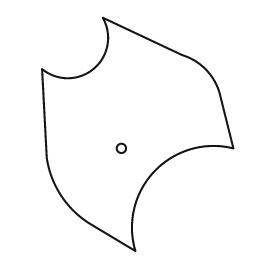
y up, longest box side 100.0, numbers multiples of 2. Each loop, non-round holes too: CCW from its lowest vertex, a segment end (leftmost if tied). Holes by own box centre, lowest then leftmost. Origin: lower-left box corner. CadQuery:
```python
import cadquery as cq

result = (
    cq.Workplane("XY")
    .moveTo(40.0, 0.0)
    .threePointArc((48.0, 34.0), (82.0, 44.0))
    .lineTo(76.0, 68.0)
    .threePointArc((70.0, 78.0), (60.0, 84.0))
    .lineTo(26.0, 100.0)
    .threePointArc((22.0, 78.0), (0.0, 78.0))
    .lineTo(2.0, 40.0)
    .threePointArc((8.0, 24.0), (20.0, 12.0))
    .close()
    .moveTo(34.0, 44.0)
    .circle(2.0)
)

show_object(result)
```